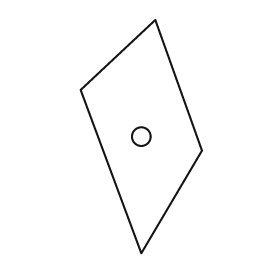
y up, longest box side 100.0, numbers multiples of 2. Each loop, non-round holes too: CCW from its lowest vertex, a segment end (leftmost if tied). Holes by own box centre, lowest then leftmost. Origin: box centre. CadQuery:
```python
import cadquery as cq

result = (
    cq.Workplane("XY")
    .moveTo(0.0, -50.0)
    .lineTo(26.0, -6.0)
    .lineTo(6.0, 50.0)
    .lineTo(-26.0, 20.0)
    .close()
    .moveTo(0.0, 0.0)
    .circle(4.0)
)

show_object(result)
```